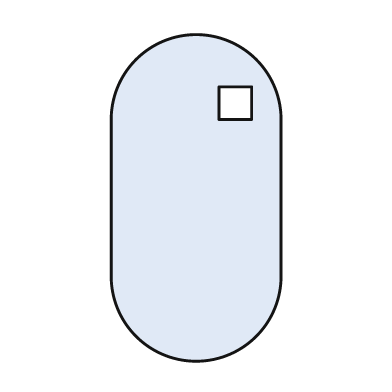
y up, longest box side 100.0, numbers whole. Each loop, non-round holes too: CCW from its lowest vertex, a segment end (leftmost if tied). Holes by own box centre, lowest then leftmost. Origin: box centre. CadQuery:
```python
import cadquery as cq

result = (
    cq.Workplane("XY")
    .moveTo(-26.0, -24.0)
    .threePointArc((0.0, -50.0), (26.0, -24.0))
    .lineTo(26.0, 24.0)
    .threePointArc((0.0, 50.0), (-26.0, 24.0))
    .close()
    .moveTo(7.0, 24.0)
    .lineTo(17.0, 24.0)
    .lineTo(17.0, 34.0)
    .lineTo(7.0, 34.0)
    .close()
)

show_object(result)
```